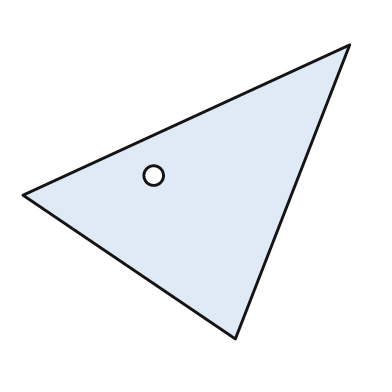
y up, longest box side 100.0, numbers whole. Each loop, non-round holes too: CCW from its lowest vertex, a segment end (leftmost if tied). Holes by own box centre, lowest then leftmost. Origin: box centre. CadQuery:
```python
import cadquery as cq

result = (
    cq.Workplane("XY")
    .moveTo(15.0, -45.0)
    .lineTo(50.0, 45.0)
    .lineTo(-50.0, -1.0)
    .close()
    .moveTo(-10.0, 5.0)
    .circle(3.0)
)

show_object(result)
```